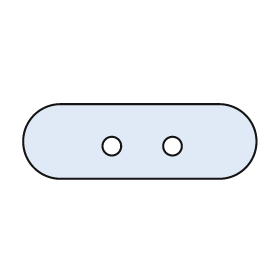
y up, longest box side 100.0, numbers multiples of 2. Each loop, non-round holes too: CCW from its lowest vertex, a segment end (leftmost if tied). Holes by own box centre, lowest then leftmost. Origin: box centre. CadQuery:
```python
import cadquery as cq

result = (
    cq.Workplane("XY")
    .moveTo(-34.0, -16.0)
    .lineTo(34.0, -16.0)
    .threePointArc((50.0, 0.0), (34.0, 16.0))
    .lineTo(-34.0, 16.0)
    .threePointArc((-50.0, 0.0), (-34.0, -16.0))
    .close()
    .moveTo(-12.0, -2.0)
    .circle(4.0)
    .moveTo(14.0, -2.0)
    .circle(4.0)
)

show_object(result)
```